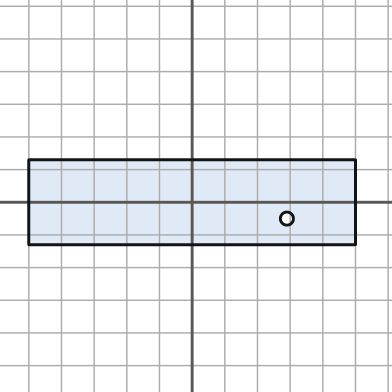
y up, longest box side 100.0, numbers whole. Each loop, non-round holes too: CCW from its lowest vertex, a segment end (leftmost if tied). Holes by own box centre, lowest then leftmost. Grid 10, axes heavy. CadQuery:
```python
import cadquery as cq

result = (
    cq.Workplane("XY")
    .moveTo(-50.0, -13.0)
    .lineTo(50.0, -13.0)
    .lineTo(50.0, 13.0)
    .lineTo(-50.0, 13.0)
    .close()
    .moveTo(29.0, -5.0)
    .circle(2.0)
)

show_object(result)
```